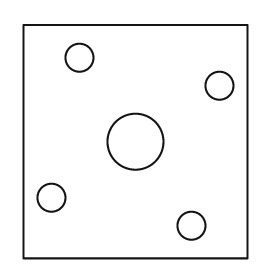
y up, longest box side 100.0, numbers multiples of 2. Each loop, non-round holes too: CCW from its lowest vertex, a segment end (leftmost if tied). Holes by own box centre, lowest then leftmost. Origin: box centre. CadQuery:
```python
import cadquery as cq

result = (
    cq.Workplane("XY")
    .moveTo(-48.0, -50.0)
    .lineTo(48.0, -50.0)
    .lineTo(48.0, 50.0)
    .lineTo(-48.0, 50.0)
    .close()
    .moveTo(24.0, -36.0)
    .circle(6.0)
    .moveTo(-36.0, -24.0)
    .circle(6.0)
    .moveTo(0.0, 0.0)
    .circle(12.0)
    .moveTo(36.0, 24.0)
    .circle(6.0)
    .moveTo(-24.0, 36.0)
    .circle(6.0)
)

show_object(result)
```